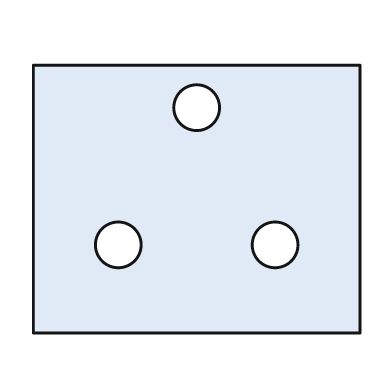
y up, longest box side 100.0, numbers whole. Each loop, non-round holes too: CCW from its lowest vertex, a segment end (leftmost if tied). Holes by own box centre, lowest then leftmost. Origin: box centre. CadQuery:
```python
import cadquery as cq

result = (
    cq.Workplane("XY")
    .moveTo(-50.0, -41.0)
    .lineTo(50.0, -41.0)
    .lineTo(50.0, 41.0)
    .lineTo(-50.0, 41.0)
    .close()
    .moveTo(-24.0, -14.0)
    .circle(7.0)
    .moveTo(24.0, -14.0)
    .circle(7.0)
    .moveTo(0.0, 28.0)
    .circle(7.0)
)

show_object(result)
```